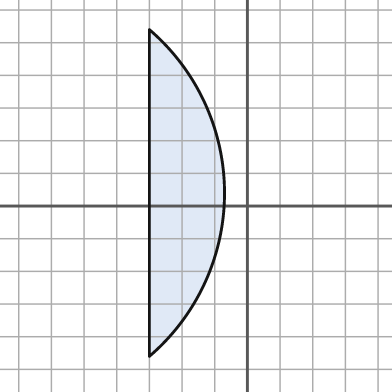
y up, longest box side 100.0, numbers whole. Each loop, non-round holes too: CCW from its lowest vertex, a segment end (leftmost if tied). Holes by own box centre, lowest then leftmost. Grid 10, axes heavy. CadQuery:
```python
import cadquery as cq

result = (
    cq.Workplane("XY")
    .moveTo(-30.0, -46.0)
    .threePointArc((-7.0, 4.0), (-30.0, 54.0))
    .close()
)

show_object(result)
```